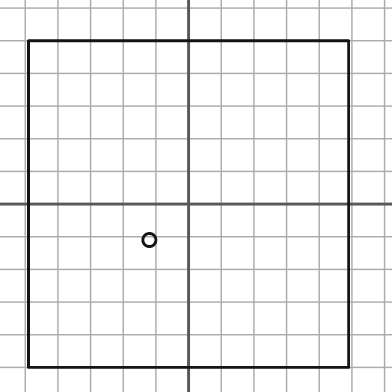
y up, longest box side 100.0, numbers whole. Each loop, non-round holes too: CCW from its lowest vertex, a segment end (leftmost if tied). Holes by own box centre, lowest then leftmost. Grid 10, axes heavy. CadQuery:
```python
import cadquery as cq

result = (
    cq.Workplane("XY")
    .moveTo(-49.0, -50.0)
    .lineTo(49.0, -50.0)
    .lineTo(49.0, 50.0)
    .lineTo(-49.0, 50.0)
    .close()
    .moveTo(-12.0, -11.0)
    .circle(2.0)
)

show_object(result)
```